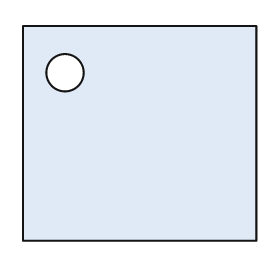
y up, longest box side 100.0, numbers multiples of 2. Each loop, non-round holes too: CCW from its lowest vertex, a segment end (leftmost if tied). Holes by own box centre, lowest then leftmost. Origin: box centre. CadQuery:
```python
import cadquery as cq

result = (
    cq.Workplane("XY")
    .moveTo(-50.0, -46.0)
    .lineTo(50.0, -46.0)
    .lineTo(50.0, 46.0)
    .lineTo(-50.0, 46.0)
    .close()
    .moveTo(-32.0, 26.0)
    .circle(8.0)
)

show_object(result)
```